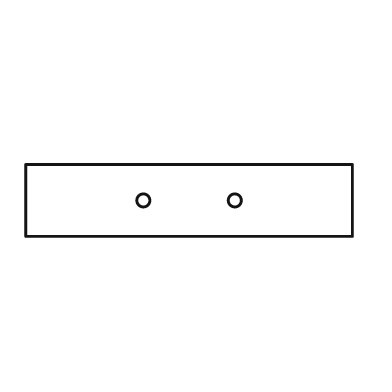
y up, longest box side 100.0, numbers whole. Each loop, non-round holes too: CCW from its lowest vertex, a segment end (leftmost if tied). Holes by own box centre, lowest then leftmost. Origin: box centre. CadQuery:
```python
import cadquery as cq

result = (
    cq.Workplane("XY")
    .moveTo(-50.0, -11.0)
    .lineTo(50.0, -11.0)
    .lineTo(50.0, 11.0)
    .lineTo(-50.0, 11.0)
    .close()
    .moveTo(-14.0, 0.0)
    .circle(2.0)
    .moveTo(14.0, 0.0)
    .circle(2.0)
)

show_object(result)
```